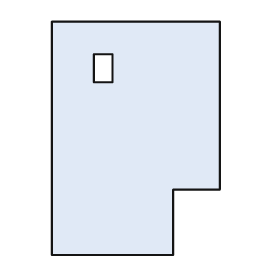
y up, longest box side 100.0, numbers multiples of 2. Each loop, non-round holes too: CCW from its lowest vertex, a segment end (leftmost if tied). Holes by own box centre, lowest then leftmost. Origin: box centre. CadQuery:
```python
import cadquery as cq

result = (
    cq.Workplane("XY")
    .moveTo(-36.0, -50.0)
    .lineTo(16.0, -50.0)
    .lineTo(16.0, -22.0)
    .lineTo(36.0, -22.0)
    .lineTo(36.0, 50.0)
    .lineTo(-36.0, 50.0)
    .close()
    .moveTo(-18.0, 24.0)
    .lineTo(-10.0, 24.0)
    .lineTo(-10.0, 36.0)
    .lineTo(-18.0, 36.0)
    .close()
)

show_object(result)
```